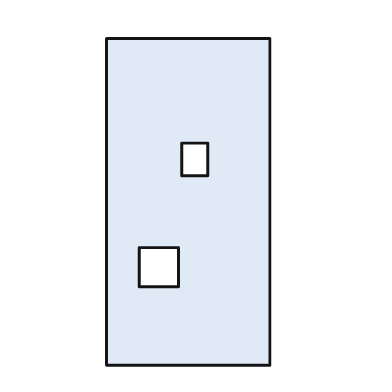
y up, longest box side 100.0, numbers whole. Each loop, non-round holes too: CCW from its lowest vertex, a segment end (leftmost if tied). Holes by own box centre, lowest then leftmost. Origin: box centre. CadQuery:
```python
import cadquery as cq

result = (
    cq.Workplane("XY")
    .moveTo(-25.0, -50.0)
    .lineTo(25.0, -50.0)
    .lineTo(25.0, 50.0)
    .lineTo(-25.0, 50.0)
    .close()
    .moveTo(-15.0, -26.0)
    .lineTo(-3.0, -26.0)
    .lineTo(-3.0, -14.0)
    .lineTo(-15.0, -14.0)
    .close()
    .moveTo(-2.0, 8.0)
    .lineTo(6.0, 8.0)
    .lineTo(6.0, 18.0)
    .lineTo(-2.0, 18.0)
    .close()
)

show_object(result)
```